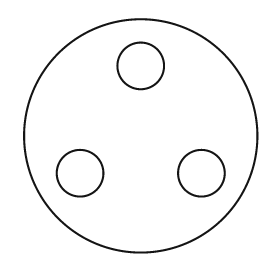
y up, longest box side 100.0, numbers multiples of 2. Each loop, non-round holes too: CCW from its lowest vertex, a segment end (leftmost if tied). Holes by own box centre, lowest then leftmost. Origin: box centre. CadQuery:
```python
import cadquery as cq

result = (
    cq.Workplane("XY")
    .moveTo(0.0, 0.0)
    .circle(50.0)
    .moveTo(-26.0, -16.0)
    .circle(10.0)
    .moveTo(26.0, -16.0)
    .circle(10.0)
    .moveTo(0.0, 30.0)
    .circle(10.0)
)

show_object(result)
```